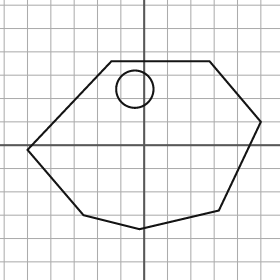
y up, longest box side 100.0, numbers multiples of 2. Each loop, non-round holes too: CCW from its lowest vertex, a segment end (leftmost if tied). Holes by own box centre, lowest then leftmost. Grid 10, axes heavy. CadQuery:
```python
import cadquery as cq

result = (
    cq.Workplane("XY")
    .moveTo(-2.0, -36.0)
    .lineTo(32.0, -28.0)
    .lineTo(50.0, 10.0)
    .lineTo(28.0, 36.0)
    .lineTo(-14.0, 36.0)
    .lineTo(-50.0, -2.0)
    .lineTo(-26.0, -30.0)
    .close()
    .moveTo(-4.0, 24.0)
    .circle(8.0)
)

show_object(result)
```